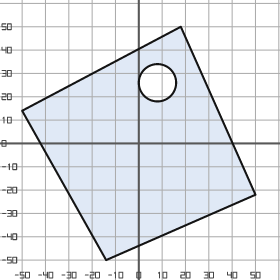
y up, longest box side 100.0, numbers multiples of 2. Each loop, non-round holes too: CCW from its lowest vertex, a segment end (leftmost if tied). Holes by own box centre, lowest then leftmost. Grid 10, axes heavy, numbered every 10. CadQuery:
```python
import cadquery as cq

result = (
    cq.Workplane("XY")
    .moveTo(-14.0, -50.0)
    .lineTo(50.0, -22.0)
    .lineTo(18.0, 50.0)
    .lineTo(-50.0, 14.0)
    .close()
    .moveTo(8.0, 26.0)
    .circle(8.0)
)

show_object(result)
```